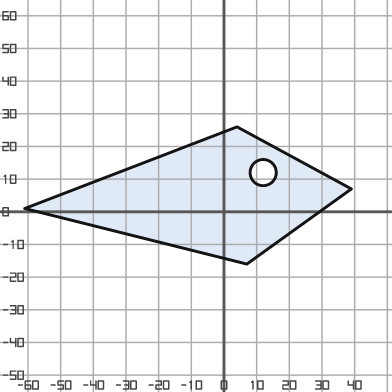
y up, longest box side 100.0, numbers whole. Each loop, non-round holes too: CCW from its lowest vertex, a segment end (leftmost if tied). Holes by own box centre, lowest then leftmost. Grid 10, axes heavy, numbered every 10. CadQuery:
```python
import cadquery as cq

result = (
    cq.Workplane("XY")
    .moveTo(7.0, -16.0)
    .lineTo(39.0, 7.0)
    .lineTo(4.0, 26.0)
    .lineTo(-61.0, 1.0)
    .close()
    .moveTo(12.0, 12.0)
    .circle(4.0)
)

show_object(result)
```